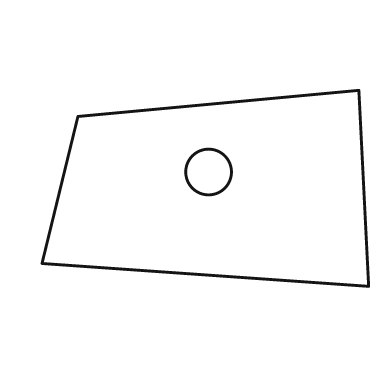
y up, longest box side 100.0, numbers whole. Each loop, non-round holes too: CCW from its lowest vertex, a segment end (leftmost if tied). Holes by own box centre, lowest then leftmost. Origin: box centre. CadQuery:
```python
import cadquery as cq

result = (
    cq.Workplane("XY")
    .moveTo(50.0, -30.0)
    .lineTo(47.0, 30.0)
    .lineTo(-39.0, 22.0)
    .lineTo(-50.0, -23.0)
    .close()
    .moveTo(1.0, 5.0)
    .circle(7.0)
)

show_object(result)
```